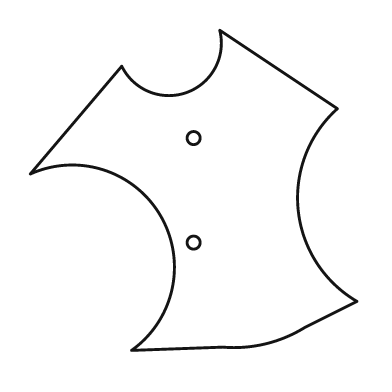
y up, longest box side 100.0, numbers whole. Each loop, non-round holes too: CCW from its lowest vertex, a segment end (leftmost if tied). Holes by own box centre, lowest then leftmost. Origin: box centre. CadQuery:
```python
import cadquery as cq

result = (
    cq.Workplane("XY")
    .moveTo(-19.0, -49.0)
    .lineTo(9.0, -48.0)
    .threePointArc((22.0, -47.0), (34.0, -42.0))
    .lineTo(50.0, -34.0)
    .threePointArc((32.0, -6.0), (44.0, 25.0))
    .lineTo(8.0, 49.0)
    .threePointArc((-2.0, 30.0), (-22.0, 38.0))
    .lineTo(-50.0, 5.0)
    .threePointArc((-10.0, -8.0), (-19.0, -49.0))
    .close()
    .moveTo(0.0, -16.0)
    .circle(2.0)
    .moveTo(0.0, 16.0)
    .circle(2.0)
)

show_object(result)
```